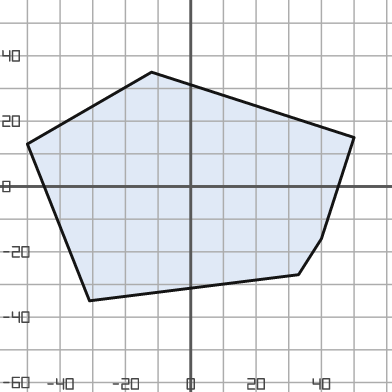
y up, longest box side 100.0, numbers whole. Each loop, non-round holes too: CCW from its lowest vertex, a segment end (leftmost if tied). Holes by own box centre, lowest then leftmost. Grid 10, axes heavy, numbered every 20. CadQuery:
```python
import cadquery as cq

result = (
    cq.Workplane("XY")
    .moveTo(-31.0, -35.0)
    .lineTo(33.0, -27.0)
    .lineTo(40.0, -16.0)
    .lineTo(50.0, 15.0)
    .lineTo(-12.0, 35.0)
    .lineTo(-50.0, 13.0)
    .close()
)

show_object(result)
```